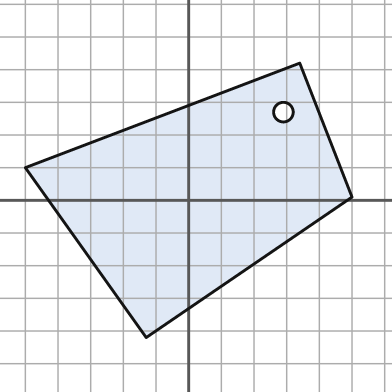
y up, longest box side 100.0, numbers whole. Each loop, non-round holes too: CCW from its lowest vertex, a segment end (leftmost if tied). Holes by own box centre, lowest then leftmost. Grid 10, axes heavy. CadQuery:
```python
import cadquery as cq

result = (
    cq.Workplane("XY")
    .moveTo(-13.0, -42.0)
    .lineTo(50.0, 1.0)
    .lineTo(34.0, 42.0)
    .lineTo(-50.0, 10.0)
    .close()
    .moveTo(29.0, 27.0)
    .circle(3.0)
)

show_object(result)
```